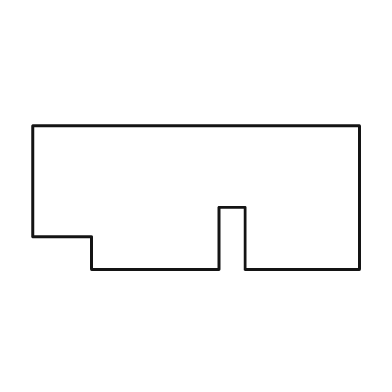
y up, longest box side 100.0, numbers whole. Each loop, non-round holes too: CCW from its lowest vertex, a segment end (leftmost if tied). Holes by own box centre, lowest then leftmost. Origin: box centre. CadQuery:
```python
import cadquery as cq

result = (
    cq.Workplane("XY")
    .moveTo(-32.0, -22.0)
    .lineTo(7.0, -22.0)
    .lineTo(7.0, -3.0)
    .lineTo(15.0, -3.0)
    .lineTo(15.0, -22.0)
    .lineTo(50.0, -22.0)
    .lineTo(50.0, 22.0)
    .lineTo(-50.0, 22.0)
    .lineTo(-50.0, -12.0)
    .lineTo(-32.0, -12.0)
    .close()
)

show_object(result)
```